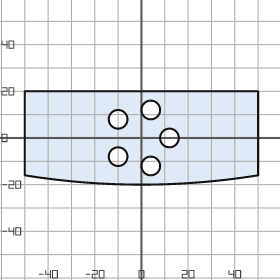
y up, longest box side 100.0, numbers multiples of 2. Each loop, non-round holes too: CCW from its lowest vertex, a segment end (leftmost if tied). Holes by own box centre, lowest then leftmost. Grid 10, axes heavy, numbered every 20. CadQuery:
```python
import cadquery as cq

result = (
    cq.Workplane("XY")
    .moveTo(-50.0, -16.0)
    .threePointArc((0.0, -20.0), (50.0, -16.0))
    .lineTo(50.0, 20.0)
    .lineTo(-50.0, 20.0)
    .close()
    .moveTo(4.0, -12.0)
    .circle(4.0)
    .moveTo(-10.0, -8.0)
    .circle(4.0)
    .moveTo(12.0, 0.0)
    .circle(4.0)
    .moveTo(-10.0, 8.0)
    .circle(4.0)
    .moveTo(4.0, 12.0)
    .circle(4.0)
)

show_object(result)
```